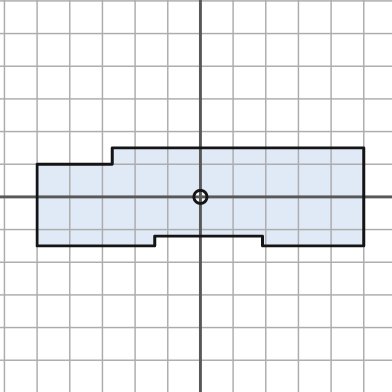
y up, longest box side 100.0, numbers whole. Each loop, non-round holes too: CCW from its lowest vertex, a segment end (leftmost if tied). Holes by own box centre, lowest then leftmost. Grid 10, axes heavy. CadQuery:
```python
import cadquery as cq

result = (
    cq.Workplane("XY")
    .moveTo(-50.0, -15.0)
    .lineTo(-14.0, -15.0)
    .lineTo(-14.0, -12.0)
    .lineTo(19.0, -12.0)
    .lineTo(19.0, -15.0)
    .lineTo(50.0, -15.0)
    .lineTo(50.0, 15.0)
    .lineTo(-27.0, 15.0)
    .lineTo(-27.0, 10.0)
    .lineTo(-50.0, 10.0)
    .close()
    .moveTo(0.0, 0.0)
    .circle(2.0)
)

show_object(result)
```